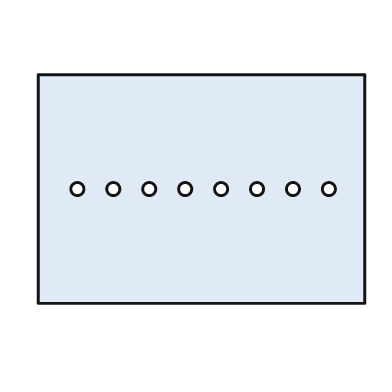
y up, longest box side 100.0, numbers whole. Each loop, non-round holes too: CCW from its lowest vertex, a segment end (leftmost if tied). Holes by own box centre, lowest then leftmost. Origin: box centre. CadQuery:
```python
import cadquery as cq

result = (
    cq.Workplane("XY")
    .moveTo(-50.0, -35.0)
    .lineTo(50.0, -35.0)
    .lineTo(50.0, 35.0)
    .lineTo(-50.0, 35.0)
    .close()
    .moveTo(-38.0, 0.0)
    .circle(2.0)
    .moveTo(-27.0, 0.0)
    .circle(2.0)
    .moveTo(-16.0, 0.0)
    .circle(2.0)
    .moveTo(-5.0, 0.0)
    .circle(2.0)
    .moveTo(6.0, 0.0)
    .circle(2.0)
    .moveTo(17.0, 0.0)
    .circle(2.0)
    .moveTo(28.0, 0.0)
    .circle(2.0)
    .moveTo(39.0, 0.0)
    .circle(2.0)
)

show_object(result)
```